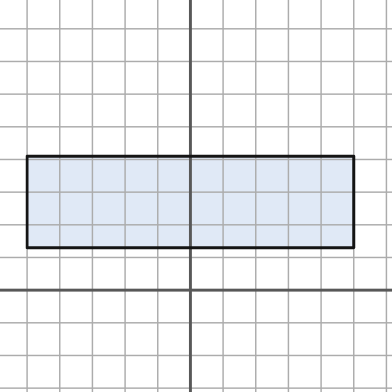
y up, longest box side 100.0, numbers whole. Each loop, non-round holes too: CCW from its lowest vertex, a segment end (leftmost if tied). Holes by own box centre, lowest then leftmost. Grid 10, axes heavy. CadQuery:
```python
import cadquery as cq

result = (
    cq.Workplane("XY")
    .moveTo(-50.0, 13.0)
    .lineTo(50.0, 13.0)
    .lineTo(50.0, 41.0)
    .lineTo(-50.0, 41.0)
    .close()
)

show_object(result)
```